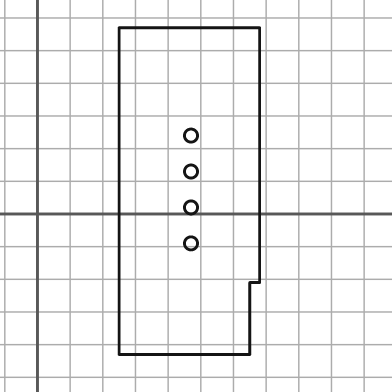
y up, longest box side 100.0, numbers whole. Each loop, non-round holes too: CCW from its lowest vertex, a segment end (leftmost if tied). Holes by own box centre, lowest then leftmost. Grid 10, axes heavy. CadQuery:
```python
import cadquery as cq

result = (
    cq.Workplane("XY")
    .moveTo(25.0, -43.0)
    .lineTo(65.0, -43.0)
    .lineTo(65.0, -21.0)
    .lineTo(68.0, -21.0)
    .lineTo(68.0, 57.0)
    .lineTo(25.0, 57.0)
    .close()
    .moveTo(47.0, -9.0)
    .circle(2.0)
    .moveTo(47.0, 2.0)
    .circle(2.0)
    .moveTo(47.0, 13.0)
    .circle(2.0)
    .moveTo(47.0, 24.0)
    .circle(2.0)
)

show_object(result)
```